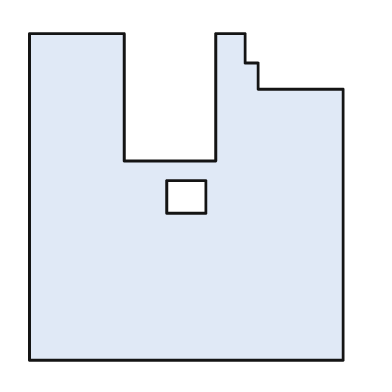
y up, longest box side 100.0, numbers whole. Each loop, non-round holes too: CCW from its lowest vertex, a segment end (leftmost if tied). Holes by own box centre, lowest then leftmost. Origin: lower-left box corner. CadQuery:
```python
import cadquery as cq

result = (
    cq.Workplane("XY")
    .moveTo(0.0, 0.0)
    .lineTo(96.0, 0.0)
    .lineTo(96.0, 83.0)
    .lineTo(70.0, 83.0)
    .lineTo(70.0, 91.0)
    .lineTo(66.0, 91.0)
    .lineTo(66.0, 100.0)
    .lineTo(57.0, 100.0)
    .lineTo(57.0, 61.0)
    .lineTo(29.0, 61.0)
    .lineTo(29.0, 100.0)
    .lineTo(0.0, 100.0)
    .close()
    .moveTo(42.0, 45.0)
    .lineTo(54.0, 45.0)
    .lineTo(54.0, 55.0)
    .lineTo(42.0, 55.0)
    .close()
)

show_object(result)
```